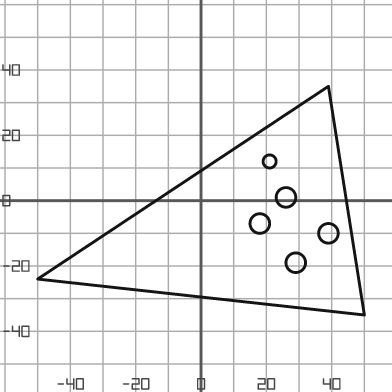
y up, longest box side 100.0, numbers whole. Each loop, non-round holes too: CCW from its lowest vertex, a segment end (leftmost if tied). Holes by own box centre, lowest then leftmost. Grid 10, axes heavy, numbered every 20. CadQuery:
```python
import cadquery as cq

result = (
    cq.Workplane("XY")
    .moveTo(50.0, -35.0)
    .lineTo(39.0, 35.0)
    .lineTo(-50.0, -24.0)
    .close()
    .moveTo(29.0, -19.0)
    .circle(3.0)
    .moveTo(39.0, -10.0)
    .circle(3.0)
    .moveTo(18.0, -7.0)
    .circle(3.0)
    .moveTo(26.0, 1.0)
    .circle(3.0)
    .moveTo(21.0, 12.0)
    .circle(2.0)
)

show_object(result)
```